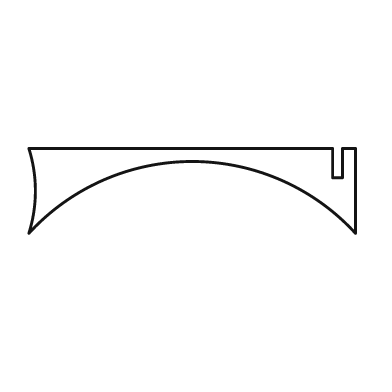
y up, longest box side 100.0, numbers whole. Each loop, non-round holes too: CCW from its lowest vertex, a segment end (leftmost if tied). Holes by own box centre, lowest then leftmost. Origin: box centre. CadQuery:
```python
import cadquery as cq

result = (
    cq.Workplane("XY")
    .moveTo(-50.0, -13.0)
    .threePointArc((0.0, 9.0), (50.0, -13.0))
    .lineTo(50.0, 13.0)
    .lineTo(46.0, 13.0)
    .lineTo(46.0, 4.0)
    .lineTo(43.0, 4.0)
    .lineTo(43.0, 13.0)
    .lineTo(-50.0, 13.0)
    .threePointArc((-48.0, 0.0), (-50.0, -13.0))
    .close()
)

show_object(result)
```